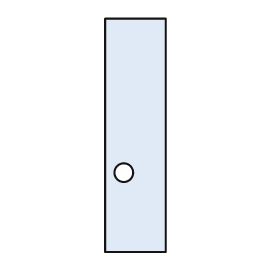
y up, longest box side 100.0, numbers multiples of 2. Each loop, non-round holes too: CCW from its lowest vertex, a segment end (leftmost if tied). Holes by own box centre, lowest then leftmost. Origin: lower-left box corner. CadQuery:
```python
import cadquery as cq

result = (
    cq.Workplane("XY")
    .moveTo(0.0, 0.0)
    .lineTo(26.0, 0.0)
    .lineTo(26.0, 100.0)
    .lineTo(0.0, 100.0)
    .close()
    .moveTo(8.0, 34.0)
    .circle(4.0)
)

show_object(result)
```